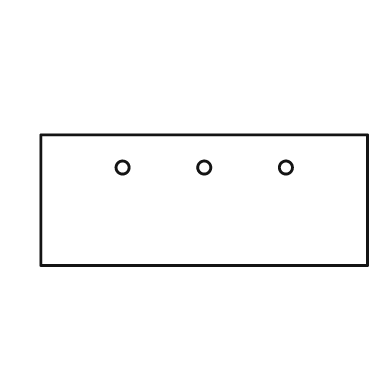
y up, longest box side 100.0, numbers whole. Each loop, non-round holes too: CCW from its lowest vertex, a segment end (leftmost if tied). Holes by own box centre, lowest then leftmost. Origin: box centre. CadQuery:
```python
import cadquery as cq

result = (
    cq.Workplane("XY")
    .moveTo(-50.0, -20.0)
    .lineTo(50.0, -20.0)
    .lineTo(50.0, 20.0)
    .lineTo(-50.0, 20.0)
    .close()
    .moveTo(-25.0, 10.0)
    .circle(2.0)
    .moveTo(0.0, 10.0)
    .circle(2.0)
    .moveTo(25.0, 10.0)
    .circle(2.0)
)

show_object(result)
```